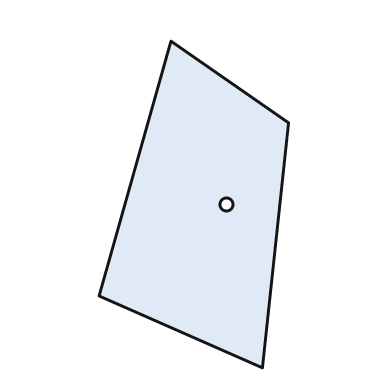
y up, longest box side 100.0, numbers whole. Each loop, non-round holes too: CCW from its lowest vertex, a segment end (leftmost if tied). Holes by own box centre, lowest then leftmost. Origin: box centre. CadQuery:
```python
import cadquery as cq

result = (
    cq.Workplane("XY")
    .moveTo(21.0, -50.0)
    .lineTo(29.0, 25.0)
    .lineTo(-7.0, 50.0)
    .lineTo(-29.0, -28.0)
    .close()
    .moveTo(10.0, 0.0)
    .circle(2.0)
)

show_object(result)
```